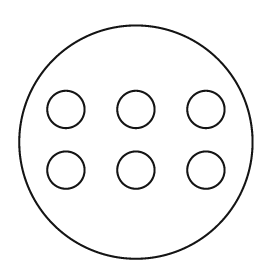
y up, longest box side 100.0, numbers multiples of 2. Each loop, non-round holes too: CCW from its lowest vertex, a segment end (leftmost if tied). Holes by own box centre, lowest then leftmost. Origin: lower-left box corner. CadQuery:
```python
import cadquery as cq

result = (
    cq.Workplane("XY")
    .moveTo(50.0, 50.0)
    .circle(50.0)
    .moveTo(20.0, 38.0)
    .circle(8.0)
    .moveTo(50.0, 38.0)
    .circle(8.0)
    .moveTo(80.0, 38.0)
    .circle(8.0)
    .moveTo(20.0, 64.0)
    .circle(8.0)
    .moveTo(50.0, 64.0)
    .circle(8.0)
    .moveTo(80.0, 64.0)
    .circle(8.0)
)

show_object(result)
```